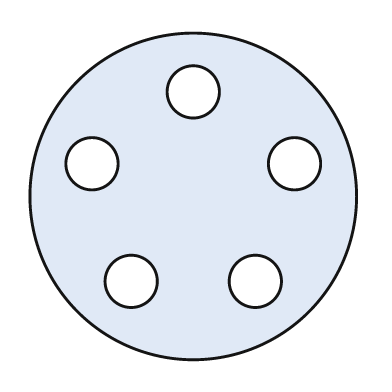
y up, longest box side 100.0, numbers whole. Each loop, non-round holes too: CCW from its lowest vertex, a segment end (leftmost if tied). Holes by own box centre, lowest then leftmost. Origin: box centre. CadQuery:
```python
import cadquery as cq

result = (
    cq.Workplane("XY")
    .moveTo(0.0, 0.0)
    .circle(50.0)
    .moveTo(-19.0, -26.0)
    .circle(8.0)
    .moveTo(19.0, -26.0)
    .circle(8.0)
    .moveTo(-31.0, 10.0)
    .circle(8.0)
    .moveTo(31.0, 10.0)
    .circle(8.0)
    .moveTo(0.0, 32.0)
    .circle(8.0)
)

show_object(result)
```